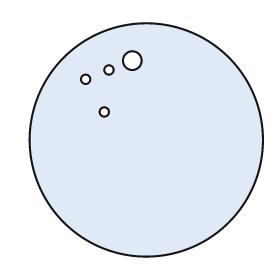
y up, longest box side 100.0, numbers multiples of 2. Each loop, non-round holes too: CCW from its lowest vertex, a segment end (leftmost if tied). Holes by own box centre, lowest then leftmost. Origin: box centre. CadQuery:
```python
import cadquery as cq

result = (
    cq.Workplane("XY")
    .moveTo(0.0, 0.0)
    .circle(50.0)
    .moveTo(-18.0, 12.0)
    .circle(2.0)
    .moveTo(-26.0, 26.0)
    .circle(2.0)
    .moveTo(-16.0, 30.0)
    .circle(2.0)
    .moveTo(-6.0, 34.0)
    .circle(4.0)
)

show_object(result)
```